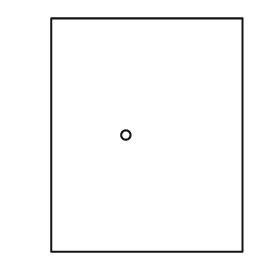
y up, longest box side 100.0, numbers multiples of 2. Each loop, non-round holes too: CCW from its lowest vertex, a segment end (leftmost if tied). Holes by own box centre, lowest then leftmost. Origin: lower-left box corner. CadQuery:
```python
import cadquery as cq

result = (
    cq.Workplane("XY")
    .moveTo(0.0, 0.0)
    .lineTo(82.0, 0.0)
    .lineTo(82.0, 100.0)
    .lineTo(0.0, 100.0)
    .close()
    .moveTo(32.0, 50.0)
    .circle(2.0)
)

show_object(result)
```